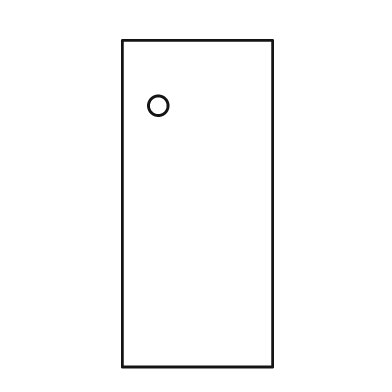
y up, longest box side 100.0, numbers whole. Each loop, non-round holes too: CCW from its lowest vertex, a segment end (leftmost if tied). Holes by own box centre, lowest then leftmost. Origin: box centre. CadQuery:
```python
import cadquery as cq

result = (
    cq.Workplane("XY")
    .moveTo(-23.0, -50.0)
    .lineTo(23.0, -50.0)
    .lineTo(23.0, 50.0)
    .lineTo(-23.0, 50.0)
    .close()
    .moveTo(-12.0, 30.0)
    .circle(3.0)
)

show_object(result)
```